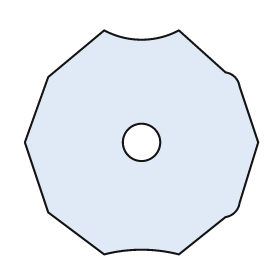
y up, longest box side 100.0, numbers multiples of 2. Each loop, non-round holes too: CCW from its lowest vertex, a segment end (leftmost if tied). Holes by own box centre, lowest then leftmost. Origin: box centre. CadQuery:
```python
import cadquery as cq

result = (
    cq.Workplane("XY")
    .moveTo(-16.0, -48.0)
    .threePointArc((0.0, -46.0), (16.0, -48.0))
    .lineTo(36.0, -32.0)
    .threePointArc((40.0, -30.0), (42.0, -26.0))
    .lineTo(50.0, 0.0)
    .lineTo(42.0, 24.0)
    .threePointArc((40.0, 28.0), (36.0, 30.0))
    .lineTo(16.0, 48.0)
    .threePointArc((0.0, 44.0), (-16.0, 48.0))
    .lineTo(-40.0, 28.0)
    .lineTo(-50.0, 0.0)
    .lineTo(-40.0, -30.0)
    .close()
    .moveTo(0.0, 0.0)
    .circle(8.0)
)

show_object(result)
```